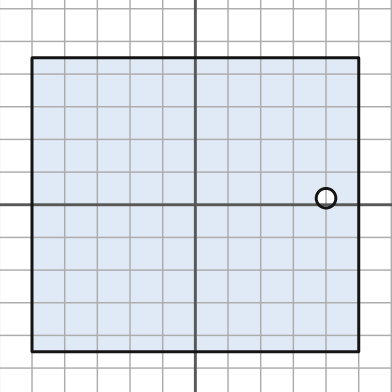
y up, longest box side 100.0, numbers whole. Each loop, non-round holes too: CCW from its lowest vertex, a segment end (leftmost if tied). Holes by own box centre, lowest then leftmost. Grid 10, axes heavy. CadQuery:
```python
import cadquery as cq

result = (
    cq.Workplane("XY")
    .moveTo(-50.0, -45.0)
    .lineTo(50.0, -45.0)
    .lineTo(50.0, 45.0)
    .lineTo(-50.0, 45.0)
    .close()
    .moveTo(40.0, 2.0)
    .circle(3.0)
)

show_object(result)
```